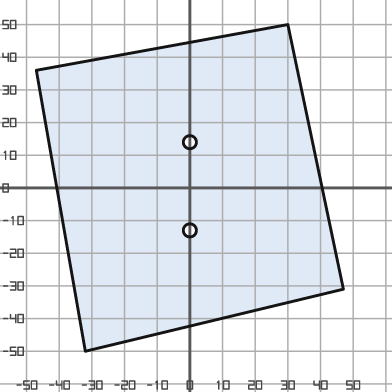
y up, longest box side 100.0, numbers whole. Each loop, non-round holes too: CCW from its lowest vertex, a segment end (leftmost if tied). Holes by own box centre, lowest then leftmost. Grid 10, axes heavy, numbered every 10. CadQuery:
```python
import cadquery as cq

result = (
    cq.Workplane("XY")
    .moveTo(-32.0, -50.0)
    .lineTo(47.0, -31.0)
    .lineTo(30.0, 50.0)
    .lineTo(-47.0, 36.0)
    .close()
    .moveTo(0.0, -13.0)
    .circle(2.0)
    .moveTo(0.0, 14.0)
    .circle(2.0)
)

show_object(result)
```